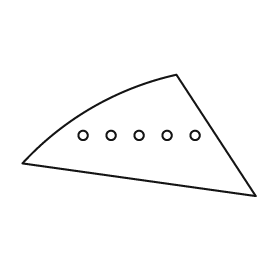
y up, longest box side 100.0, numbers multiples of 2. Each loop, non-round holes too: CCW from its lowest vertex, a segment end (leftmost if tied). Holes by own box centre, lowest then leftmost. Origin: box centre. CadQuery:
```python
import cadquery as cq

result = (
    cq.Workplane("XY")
    .moveTo(50.0, -26.0)
    .lineTo(16.0, 26.0)
    .threePointArc((-20.0, 12.0), (-50.0, -12.0))
    .close()
    .moveTo(-24.0, 0.0)
    .circle(2.0)
    .moveTo(-12.0, 0.0)
    .circle(2.0)
    .moveTo(0.0, 0.0)
    .circle(2.0)
    .moveTo(12.0, 0.0)
    .circle(2.0)
    .moveTo(24.0, 0.0)
    .circle(2.0)
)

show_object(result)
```